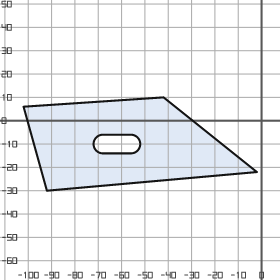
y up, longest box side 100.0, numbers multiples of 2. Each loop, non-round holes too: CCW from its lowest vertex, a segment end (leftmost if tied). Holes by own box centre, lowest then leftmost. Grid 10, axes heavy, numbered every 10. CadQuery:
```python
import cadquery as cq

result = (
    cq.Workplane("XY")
    .moveTo(-92.0, -30.0)
    .lineTo(-2.0, -22.0)
    .lineTo(-42.0, 10.0)
    .lineTo(-102.0, 6.0)
    .close()
    .moveTo(-68.0, -14.0)
    .lineTo(-56.0, -14.0)
    .threePointArc((-52.0, -10.0), (-56.0, -6.0))
    .lineTo(-68.0, -6.0)
    .threePointArc((-72.0, -10.0), (-68.0, -14.0))
    .close()
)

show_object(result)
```